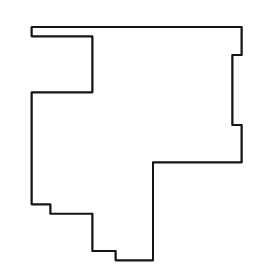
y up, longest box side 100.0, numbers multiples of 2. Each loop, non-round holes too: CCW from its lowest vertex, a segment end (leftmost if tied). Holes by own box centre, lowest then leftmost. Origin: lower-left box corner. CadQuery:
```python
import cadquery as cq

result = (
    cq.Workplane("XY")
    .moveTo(36.0, 0.0)
    .lineTo(52.0, 0.0)
    .lineTo(52.0, 42.0)
    .lineTo(90.0, 42.0)
    .lineTo(90.0, 58.0)
    .lineTo(86.0, 58.0)
    .lineTo(86.0, 88.0)
    .lineTo(90.0, 88.0)
    .lineTo(90.0, 100.0)
    .lineTo(0.0, 100.0)
    .lineTo(0.0, 96.0)
    .lineTo(26.0, 96.0)
    .lineTo(26.0, 72.0)
    .lineTo(0.0, 72.0)
    .lineTo(0.0, 24.0)
    .lineTo(8.0, 24.0)
    .lineTo(8.0, 20.0)
    .lineTo(26.0, 20.0)
    .lineTo(26.0, 4.0)
    .lineTo(36.0, 4.0)
    .close()
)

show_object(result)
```